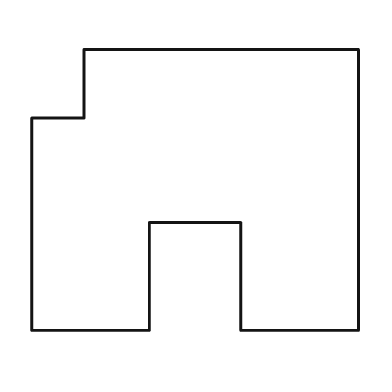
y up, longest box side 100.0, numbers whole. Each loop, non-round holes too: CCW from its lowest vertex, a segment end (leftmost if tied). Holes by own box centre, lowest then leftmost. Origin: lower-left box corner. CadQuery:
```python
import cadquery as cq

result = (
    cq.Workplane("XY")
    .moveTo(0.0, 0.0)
    .lineTo(36.0, 0.0)
    .lineTo(36.0, 33.0)
    .lineTo(64.0, 33.0)
    .lineTo(64.0, 0.0)
    .lineTo(100.0, 0.0)
    .lineTo(100.0, 86.0)
    .lineTo(16.0, 86.0)
    .lineTo(16.0, 65.0)
    .lineTo(0.0, 65.0)
    .close()
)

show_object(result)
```